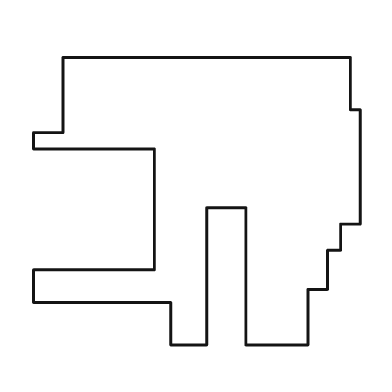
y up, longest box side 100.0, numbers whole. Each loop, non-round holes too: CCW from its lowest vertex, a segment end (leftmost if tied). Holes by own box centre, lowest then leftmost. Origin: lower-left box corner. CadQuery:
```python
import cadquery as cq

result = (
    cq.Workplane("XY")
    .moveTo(42.0, 0.0)
    .lineTo(53.0, 0.0)
    .lineTo(53.0, 42.0)
    .lineTo(65.0, 42.0)
    .lineTo(65.0, 0.0)
    .lineTo(84.0, 0.0)
    .lineTo(84.0, 17.0)
    .lineTo(90.0, 17.0)
    .lineTo(90.0, 29.0)
    .lineTo(94.0, 29.0)
    .lineTo(94.0, 37.0)
    .lineTo(100.0, 37.0)
    .lineTo(100.0, 72.0)
    .lineTo(97.0, 72.0)
    .lineTo(97.0, 88.0)
    .lineTo(9.0, 88.0)
    .lineTo(9.0, 65.0)
    .lineTo(0.0, 65.0)
    .lineTo(0.0, 60.0)
    .lineTo(37.0, 60.0)
    .lineTo(37.0, 23.0)
    .lineTo(0.0, 23.0)
    .lineTo(0.0, 13.0)
    .lineTo(42.0, 13.0)
    .close()
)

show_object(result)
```